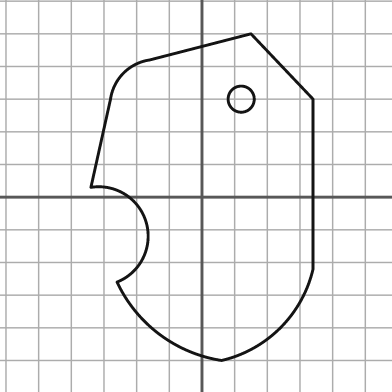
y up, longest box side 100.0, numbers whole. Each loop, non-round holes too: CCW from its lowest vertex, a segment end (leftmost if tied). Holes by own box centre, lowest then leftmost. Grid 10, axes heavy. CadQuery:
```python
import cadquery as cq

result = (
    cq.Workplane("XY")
    .moveTo(6.0, -50.0)
    .threePointArc((24.0, -40.0), (34.0, -22.0))
    .lineTo(34.0, 30.0)
    .lineTo(15.0, 50.0)
    .lineTo(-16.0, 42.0)
    .threePointArc((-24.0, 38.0), (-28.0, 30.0))
    .lineTo(-34.0, 3.0)
    .threePointArc((-17.0, -8.0), (-26.0, -26.0))
    .threePointArc((-13.0, -42.0), (6.0, -50.0))
    .close()
    .moveTo(12.0, 30.0)
    .circle(4.0)
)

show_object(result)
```